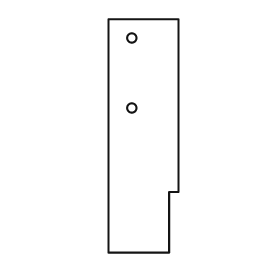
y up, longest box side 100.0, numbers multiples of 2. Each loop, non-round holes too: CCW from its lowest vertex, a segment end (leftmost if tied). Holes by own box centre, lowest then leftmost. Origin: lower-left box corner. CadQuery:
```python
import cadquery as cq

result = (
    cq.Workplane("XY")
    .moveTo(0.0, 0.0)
    .lineTo(26.0, 0.0)
    .lineTo(26.0, 26.0)
    .lineTo(30.0, 26.0)
    .lineTo(30.0, 100.0)
    .lineTo(0.0, 100.0)
    .close()
    .moveTo(10.0, 62.0)
    .circle(2.0)
    .moveTo(10.0, 92.0)
    .circle(2.0)
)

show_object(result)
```